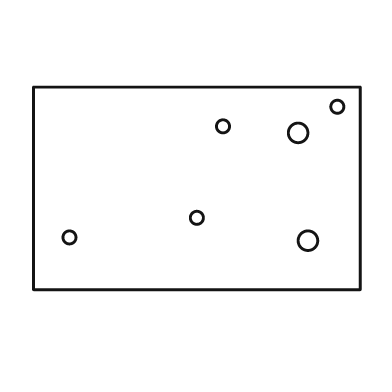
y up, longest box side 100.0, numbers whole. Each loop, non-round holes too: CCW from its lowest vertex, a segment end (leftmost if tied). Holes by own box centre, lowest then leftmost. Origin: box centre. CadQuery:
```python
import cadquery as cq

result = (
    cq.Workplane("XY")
    .moveTo(-50.0, -31.0)
    .lineTo(50.0, -31.0)
    .lineTo(50.0, 31.0)
    .lineTo(-50.0, 31.0)
    .close()
    .moveTo(34.0, -16.0)
    .circle(3.0)
    .moveTo(-39.0, -15.0)
    .circle(2.0)
    .moveTo(0.0, -9.0)
    .circle(2.0)
    .moveTo(31.0, 17.0)
    .circle(3.0)
    .moveTo(8.0, 19.0)
    .circle(2.0)
    .moveTo(43.0, 25.0)
    .circle(2.0)
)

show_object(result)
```